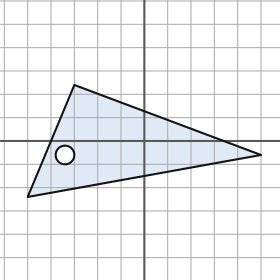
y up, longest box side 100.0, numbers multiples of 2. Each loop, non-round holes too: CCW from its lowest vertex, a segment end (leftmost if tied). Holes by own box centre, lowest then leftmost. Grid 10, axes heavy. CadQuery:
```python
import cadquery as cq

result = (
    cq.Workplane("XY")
    .moveTo(-50.0, -24.0)
    .lineTo(50.0, -6.0)
    .lineTo(-30.0, 24.0)
    .close()
    .moveTo(-34.0, -6.0)
    .circle(4.0)
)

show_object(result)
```